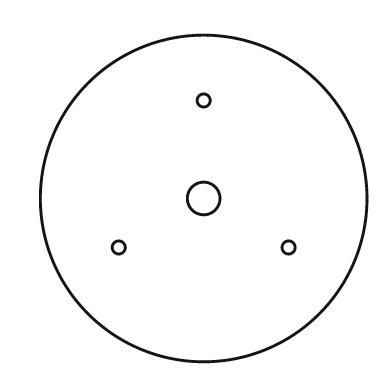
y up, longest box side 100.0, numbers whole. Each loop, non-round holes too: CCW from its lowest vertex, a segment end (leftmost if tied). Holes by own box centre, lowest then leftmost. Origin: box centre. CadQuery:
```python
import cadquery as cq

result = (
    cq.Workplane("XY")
    .moveTo(0.0, 0.0)
    .circle(50.0)
    .moveTo(-26.0, -15.0)
    .circle(2.0)
    .moveTo(26.0, -15.0)
    .circle(2.0)
    .moveTo(0.0, 0.0)
    .circle(5.0)
    .moveTo(0.0, 30.0)
    .circle(2.0)
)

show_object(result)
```